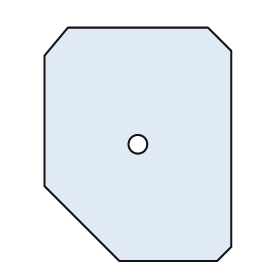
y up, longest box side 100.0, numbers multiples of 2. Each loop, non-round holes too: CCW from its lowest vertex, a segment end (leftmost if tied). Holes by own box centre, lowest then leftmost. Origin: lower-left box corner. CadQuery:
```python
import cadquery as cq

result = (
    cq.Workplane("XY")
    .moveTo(32.0, 0.0)
    .lineTo(74.0, 0.0)
    .lineTo(80.0, 6.0)
    .lineTo(80.0, 90.0)
    .lineTo(70.0, 100.0)
    .lineTo(10.0, 100.0)
    .lineTo(0.0, 88.0)
    .lineTo(0.0, 32.0)
    .close()
    .moveTo(40.0, 50.0)
    .circle(4.0)
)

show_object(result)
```